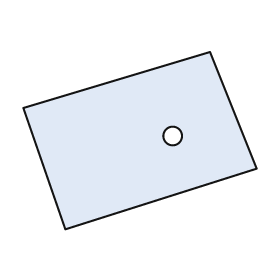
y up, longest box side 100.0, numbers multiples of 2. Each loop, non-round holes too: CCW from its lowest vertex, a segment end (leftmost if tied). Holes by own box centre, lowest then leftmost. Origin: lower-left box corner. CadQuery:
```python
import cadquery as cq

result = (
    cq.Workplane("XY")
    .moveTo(18.0, 0.0)
    .lineTo(100.0, 26.0)
    .lineTo(80.0, 76.0)
    .lineTo(0.0, 52.0)
    .close()
    .moveTo(64.0, 40.0)
    .circle(4.0)
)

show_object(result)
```